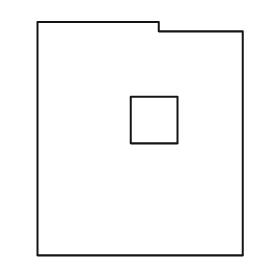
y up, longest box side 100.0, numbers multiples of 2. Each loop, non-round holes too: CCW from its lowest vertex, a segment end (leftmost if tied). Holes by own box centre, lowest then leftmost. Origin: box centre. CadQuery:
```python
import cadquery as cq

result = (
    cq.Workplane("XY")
    .moveTo(-44.0, -50.0)
    .lineTo(44.0, -50.0)
    .lineTo(44.0, 46.0)
    .lineTo(8.0, 46.0)
    .lineTo(8.0, 50.0)
    .lineTo(-44.0, 50.0)
    .close()
    .moveTo(-4.0, -2.0)
    .lineTo(16.0, -2.0)
    .lineTo(16.0, 18.0)
    .lineTo(-4.0, 18.0)
    .close()
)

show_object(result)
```